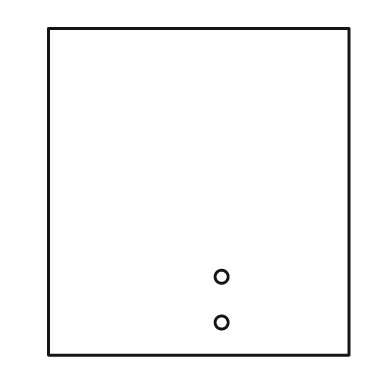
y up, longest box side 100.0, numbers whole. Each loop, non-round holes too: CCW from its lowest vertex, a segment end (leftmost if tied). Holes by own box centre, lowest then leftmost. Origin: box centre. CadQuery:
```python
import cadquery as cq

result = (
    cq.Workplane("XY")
    .moveTo(-46.0, -50.0)
    .lineTo(46.0, -50.0)
    .lineTo(46.0, 50.0)
    .lineTo(-46.0, 50.0)
    .close()
    .moveTo(7.0, -40.0)
    .circle(2.0)
    .moveTo(7.0, -26.0)
    .circle(2.0)
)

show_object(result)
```